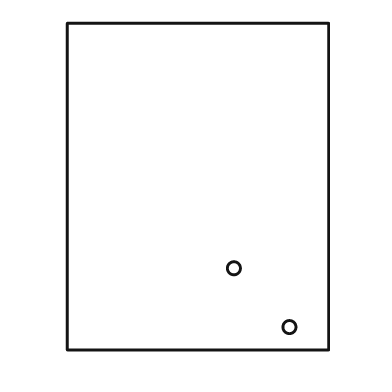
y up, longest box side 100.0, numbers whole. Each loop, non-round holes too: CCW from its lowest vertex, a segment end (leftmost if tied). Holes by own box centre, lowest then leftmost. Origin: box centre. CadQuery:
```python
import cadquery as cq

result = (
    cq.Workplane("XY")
    .moveTo(-40.0, -50.0)
    .lineTo(40.0, -50.0)
    .lineTo(40.0, 50.0)
    .lineTo(-40.0, 50.0)
    .close()
    .moveTo(28.0, -43.0)
    .circle(2.0)
    .moveTo(11.0, -25.0)
    .circle(2.0)
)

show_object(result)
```